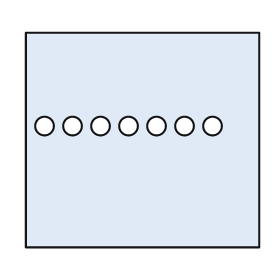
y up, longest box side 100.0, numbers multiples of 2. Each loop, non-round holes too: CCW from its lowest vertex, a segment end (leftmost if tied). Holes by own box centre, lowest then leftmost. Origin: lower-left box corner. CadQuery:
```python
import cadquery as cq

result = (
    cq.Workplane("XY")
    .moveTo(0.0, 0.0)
    .lineTo(100.0, 0.0)
    .lineTo(100.0, 92.0)
    .lineTo(0.0, 92.0)
    .close()
    .moveTo(8.0, 52.0)
    .circle(4.0)
    .moveTo(20.0, 52.0)
    .circle(4.0)
    .moveTo(32.0, 52.0)
    .circle(4.0)
    .moveTo(44.0, 52.0)
    .circle(4.0)
    .moveTo(56.0, 52.0)
    .circle(4.0)
    .moveTo(68.0, 52.0)
    .circle(4.0)
    .moveTo(80.0, 52.0)
    .circle(4.0)
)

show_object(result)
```